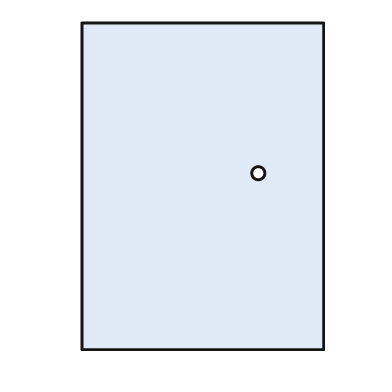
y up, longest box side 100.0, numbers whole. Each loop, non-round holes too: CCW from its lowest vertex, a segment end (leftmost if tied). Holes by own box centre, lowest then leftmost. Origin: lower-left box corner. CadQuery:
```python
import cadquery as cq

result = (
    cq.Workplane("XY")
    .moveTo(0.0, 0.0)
    .lineTo(74.0, 0.0)
    .lineTo(74.0, 100.0)
    .lineTo(0.0, 100.0)
    .close()
    .moveTo(54.0, 54.0)
    .circle(2.0)
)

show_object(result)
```